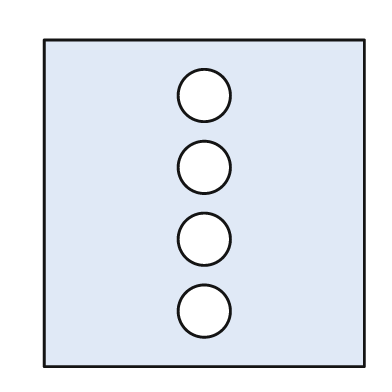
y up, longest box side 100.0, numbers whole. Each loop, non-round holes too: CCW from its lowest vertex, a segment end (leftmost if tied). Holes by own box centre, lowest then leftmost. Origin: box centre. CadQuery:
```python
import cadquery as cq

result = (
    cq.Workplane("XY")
    .moveTo(-49.0, -50.0)
    .lineTo(49.0, -50.0)
    .lineTo(49.0, 50.0)
    .lineTo(-49.0, 50.0)
    .close()
    .moveTo(0.0, -33.0)
    .circle(8.0)
    .moveTo(0.0, -11.0)
    .circle(8.0)
    .moveTo(0.0, 11.0)
    .circle(8.0)
    .moveTo(0.0, 33.0)
    .circle(8.0)
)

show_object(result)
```